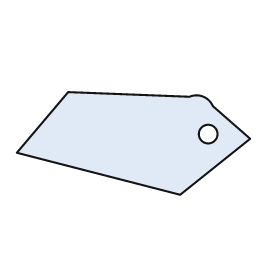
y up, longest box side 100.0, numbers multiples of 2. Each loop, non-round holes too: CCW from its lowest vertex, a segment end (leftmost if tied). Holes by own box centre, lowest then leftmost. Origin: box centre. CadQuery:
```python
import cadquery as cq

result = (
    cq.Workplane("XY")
    .moveTo(20.0, -22.0)
    .lineTo(50.0, 2.0)
    .lineTo(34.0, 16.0)
    .threePointArc((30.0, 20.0), (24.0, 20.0))
    .lineTo(-28.0, 22.0)
    .lineTo(-50.0, -4.0)
    .close()
    .moveTo(32.0, 4.0)
    .circle(4.0)
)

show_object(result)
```